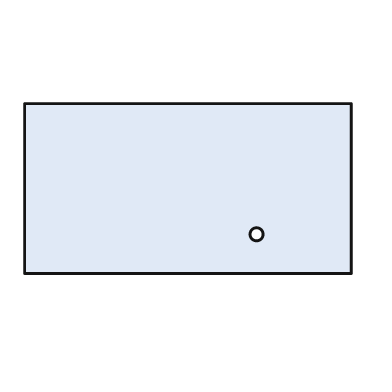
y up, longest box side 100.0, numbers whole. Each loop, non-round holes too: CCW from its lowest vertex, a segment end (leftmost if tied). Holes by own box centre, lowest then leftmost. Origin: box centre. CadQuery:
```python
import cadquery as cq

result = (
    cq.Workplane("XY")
    .moveTo(-50.0, -26.0)
    .lineTo(50.0, -26.0)
    .lineTo(50.0, 26.0)
    .lineTo(-50.0, 26.0)
    .close()
    .moveTo(21.0, -14.0)
    .circle(2.0)
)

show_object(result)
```